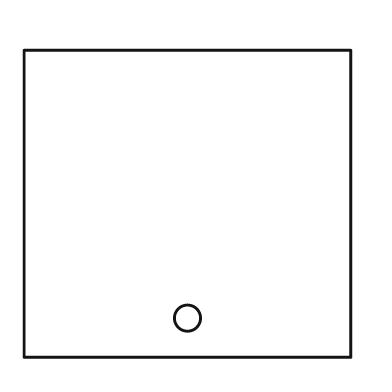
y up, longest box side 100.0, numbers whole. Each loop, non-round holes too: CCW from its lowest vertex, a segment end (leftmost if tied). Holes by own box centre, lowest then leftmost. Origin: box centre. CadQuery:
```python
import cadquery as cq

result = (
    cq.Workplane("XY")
    .moveTo(-50.0, -47.0)
    .lineTo(50.0, -47.0)
    .lineTo(50.0, 47.0)
    .lineTo(-50.0, 47.0)
    .close()
    .moveTo(0.0, -35.0)
    .circle(4.0)
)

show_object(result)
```